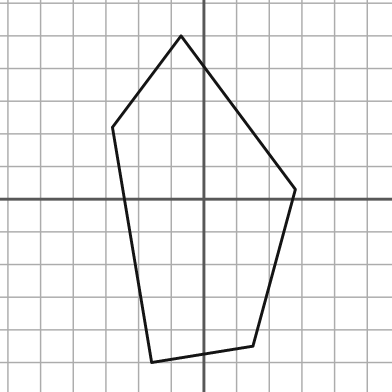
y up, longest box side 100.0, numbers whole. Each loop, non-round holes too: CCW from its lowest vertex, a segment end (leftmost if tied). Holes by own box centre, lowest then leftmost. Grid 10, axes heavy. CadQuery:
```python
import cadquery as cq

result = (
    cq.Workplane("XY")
    .moveTo(-16.0, -50.0)
    .lineTo(15.0, -45.0)
    .lineTo(28.0, 3.0)
    .lineTo(-7.0, 50.0)
    .lineTo(-28.0, 22.0)
    .close()
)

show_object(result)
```